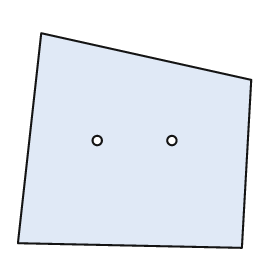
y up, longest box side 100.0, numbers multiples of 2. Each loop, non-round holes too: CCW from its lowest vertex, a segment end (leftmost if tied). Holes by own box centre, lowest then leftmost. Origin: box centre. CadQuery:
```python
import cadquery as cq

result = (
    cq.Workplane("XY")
    .moveTo(46.0, -46.0)
    .lineTo(50.0, 26.0)
    .lineTo(-40.0, 46.0)
    .lineTo(-50.0, -44.0)
    .close()
    .moveTo(-16.0, 0.0)
    .circle(2.0)
    .moveTo(16.0, 0.0)
    .circle(2.0)
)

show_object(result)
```